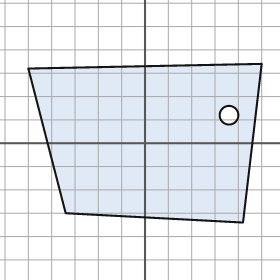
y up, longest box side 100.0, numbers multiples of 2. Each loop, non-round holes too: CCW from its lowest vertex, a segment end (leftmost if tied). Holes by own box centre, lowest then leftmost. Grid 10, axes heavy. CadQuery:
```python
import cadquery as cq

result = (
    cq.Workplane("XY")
    .moveTo(42.0, -34.0)
    .lineTo(50.0, 34.0)
    .lineTo(-50.0, 32.0)
    .lineTo(-34.0, -30.0)
    .close()
    .moveTo(36.0, 12.0)
    .circle(4.0)
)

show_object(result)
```